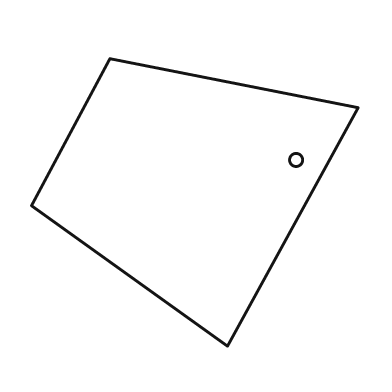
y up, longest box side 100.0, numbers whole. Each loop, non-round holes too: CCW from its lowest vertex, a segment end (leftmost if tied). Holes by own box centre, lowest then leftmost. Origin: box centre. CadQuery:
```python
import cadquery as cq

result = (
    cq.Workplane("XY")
    .moveTo(10.0, -44.0)
    .lineTo(50.0, 29.0)
    .lineTo(-26.0, 44.0)
    .lineTo(-50.0, -1.0)
    .close()
    .moveTo(31.0, 13.0)
    .circle(2.0)
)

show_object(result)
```